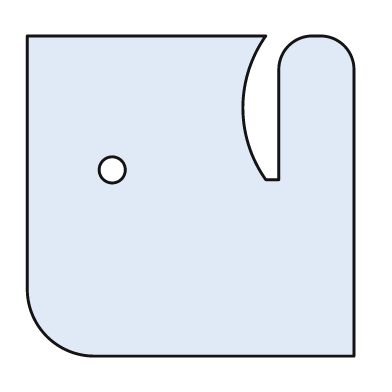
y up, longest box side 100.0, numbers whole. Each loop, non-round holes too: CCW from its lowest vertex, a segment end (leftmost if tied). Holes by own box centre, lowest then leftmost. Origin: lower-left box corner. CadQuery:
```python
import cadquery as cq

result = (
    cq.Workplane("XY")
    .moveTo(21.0, 0.0)
    .lineTo(100.0, 0.0)
    .lineTo(100.0, 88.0)
    .threePointArc((97.0, 95.0), (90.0, 98.0))
    .lineTo(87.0, 98.0)
    .threePointArc((80.0, 95.0), (77.0, 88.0))
    .lineTo(77.0, 54.0)
    .lineTo(73.0, 54.0)
    .threePointArc((66.0, 76.0), (73.0, 98.0))
    .lineTo(0.0, 98.0)
    .lineTo(0.0, 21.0)
    .threePointArc((6.0, 6.0), (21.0, 0.0))
    .close()
    .moveTo(26.0, 57.0)
    .circle(4.0)
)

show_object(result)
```